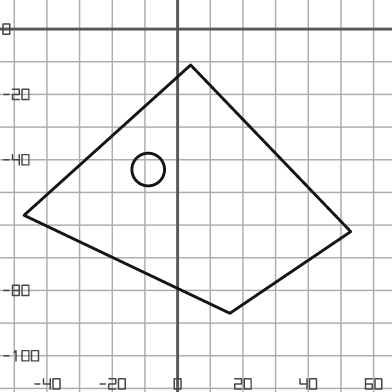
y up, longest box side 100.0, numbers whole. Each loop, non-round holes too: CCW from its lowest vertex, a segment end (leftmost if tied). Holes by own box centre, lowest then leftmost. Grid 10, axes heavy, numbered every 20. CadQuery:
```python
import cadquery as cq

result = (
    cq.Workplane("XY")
    .moveTo(16.0, -87.0)
    .lineTo(53.0, -62.0)
    .lineTo(4.0, -11.0)
    .lineTo(-47.0, -57.0)
    .close()
    .moveTo(-9.0, -43.0)
    .circle(5.0)
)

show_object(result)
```